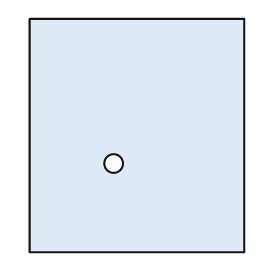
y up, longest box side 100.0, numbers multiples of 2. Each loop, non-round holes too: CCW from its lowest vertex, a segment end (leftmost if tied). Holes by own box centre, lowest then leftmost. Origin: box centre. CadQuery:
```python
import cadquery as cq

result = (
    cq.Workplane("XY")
    .moveTo(-46.0, -50.0)
    .lineTo(46.0, -50.0)
    .lineTo(46.0, 50.0)
    .lineTo(-46.0, 50.0)
    .close()
    .moveTo(-10.0, -12.0)
    .circle(4.0)
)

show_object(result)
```